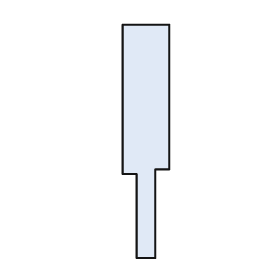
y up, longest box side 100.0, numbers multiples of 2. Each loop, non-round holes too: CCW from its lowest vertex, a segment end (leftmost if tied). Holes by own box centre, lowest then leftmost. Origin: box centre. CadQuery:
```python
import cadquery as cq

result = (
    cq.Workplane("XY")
    .moveTo(-4.0, -50.0)
    .lineTo(4.0, -50.0)
    .lineTo(4.0, -12.0)
    .lineTo(10.0, -12.0)
    .lineTo(10.0, 50.0)
    .lineTo(-10.0, 50.0)
    .lineTo(-10.0, -14.0)
    .lineTo(-4.0, -14.0)
    .close()
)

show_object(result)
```